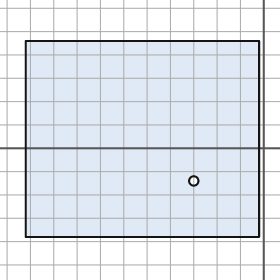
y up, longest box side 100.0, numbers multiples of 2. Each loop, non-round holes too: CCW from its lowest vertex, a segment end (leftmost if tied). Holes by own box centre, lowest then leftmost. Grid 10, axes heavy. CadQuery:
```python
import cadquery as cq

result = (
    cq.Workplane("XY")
    .moveTo(-102.0, -38.0)
    .lineTo(-2.0, -38.0)
    .lineTo(-2.0, 46.0)
    .lineTo(-102.0, 46.0)
    .close()
    .moveTo(-30.0, -14.0)
    .circle(2.0)
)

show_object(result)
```